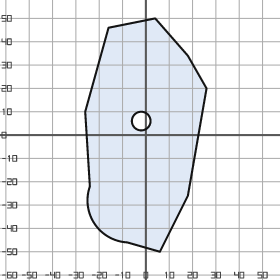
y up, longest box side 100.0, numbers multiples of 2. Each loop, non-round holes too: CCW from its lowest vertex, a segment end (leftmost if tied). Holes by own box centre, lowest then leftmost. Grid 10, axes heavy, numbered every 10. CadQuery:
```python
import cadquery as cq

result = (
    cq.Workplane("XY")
    .moveTo(6.0, -50.0)
    .lineTo(18.0, -26.0)
    .lineTo(26.0, 20.0)
    .lineTo(18.0, 34.0)
    .lineTo(4.0, 50.0)
    .lineTo(-16.0, 46.0)
    .lineTo(-26.0, 10.0)
    .lineTo(-24.0, -22.0)
    .threePointArc((-22.0, -38.0), (-8.0, -46.0))
    .close()
    .moveTo(-2.0, 6.0)
    .circle(4.0)
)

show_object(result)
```